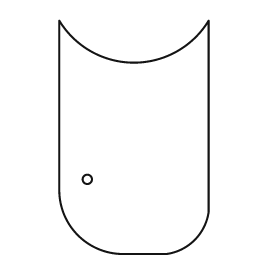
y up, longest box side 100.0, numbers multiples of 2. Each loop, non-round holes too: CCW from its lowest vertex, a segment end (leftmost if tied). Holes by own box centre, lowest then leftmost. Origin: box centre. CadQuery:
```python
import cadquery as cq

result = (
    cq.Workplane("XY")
    .moveTo(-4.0, -50.0)
    .lineTo(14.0, -50.0)
    .threePointArc((26.0, -44.0), (32.0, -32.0))
    .lineTo(32.0, 50.0)
    .threePointArc((0.0, 32.0), (-32.0, 50.0))
    .lineTo(-32.0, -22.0)
    .threePointArc((-24.0, -42.0), (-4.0, -50.0))
    .close()
    .moveTo(-20.0, -18.0)
    .circle(2.0)
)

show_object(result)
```